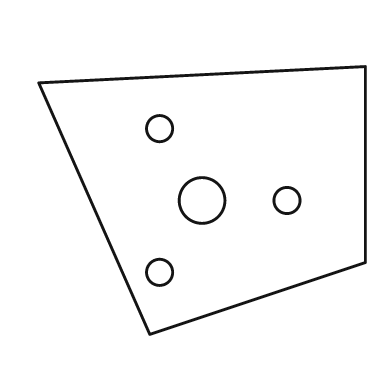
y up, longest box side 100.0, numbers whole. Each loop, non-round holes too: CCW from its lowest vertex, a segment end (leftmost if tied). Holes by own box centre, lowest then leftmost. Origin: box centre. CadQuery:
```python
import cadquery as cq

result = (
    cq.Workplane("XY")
    .moveTo(-16.0, -41.0)
    .lineTo(50.0, -19.0)
    .lineTo(50.0, 41.0)
    .lineTo(-50.0, 36.0)
    .close()
    .moveTo(-13.0, -22.0)
    .circle(4.0)
    .moveTo(0.0, 0.0)
    .circle(7.0)
    .moveTo(26.0, 0.0)
    .circle(4.0)
    .moveTo(-13.0, 22.0)
    .circle(4.0)
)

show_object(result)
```